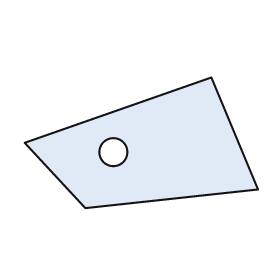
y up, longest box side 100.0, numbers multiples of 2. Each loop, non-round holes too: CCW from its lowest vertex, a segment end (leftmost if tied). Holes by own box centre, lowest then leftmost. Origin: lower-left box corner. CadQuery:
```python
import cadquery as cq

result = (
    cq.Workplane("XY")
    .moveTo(26.0, 0.0)
    .lineTo(100.0, 8.0)
    .lineTo(80.0, 56.0)
    .lineTo(0.0, 28.0)
    .close()
    .moveTo(38.0, 24.0)
    .circle(6.0)
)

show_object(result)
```